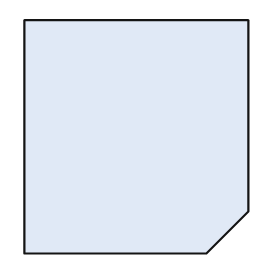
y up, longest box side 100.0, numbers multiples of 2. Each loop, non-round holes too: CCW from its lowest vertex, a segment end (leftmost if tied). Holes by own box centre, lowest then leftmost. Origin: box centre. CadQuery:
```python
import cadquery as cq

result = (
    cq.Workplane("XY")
    .moveTo(-48.0, -50.0)
    .lineTo(30.0, -50.0)
    .lineTo(48.0, -32.0)
    .lineTo(48.0, 50.0)
    .lineTo(-48.0, 50.0)
    .close()
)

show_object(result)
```